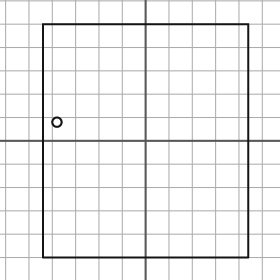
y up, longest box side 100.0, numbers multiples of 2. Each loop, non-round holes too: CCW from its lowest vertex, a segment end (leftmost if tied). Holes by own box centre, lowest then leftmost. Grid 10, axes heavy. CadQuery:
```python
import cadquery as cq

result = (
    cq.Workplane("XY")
    .moveTo(-44.0, -50.0)
    .lineTo(44.0, -50.0)
    .lineTo(44.0, 50.0)
    .lineTo(-44.0, 50.0)
    .close()
    .moveTo(-38.0, 8.0)
    .circle(2.0)
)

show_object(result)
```